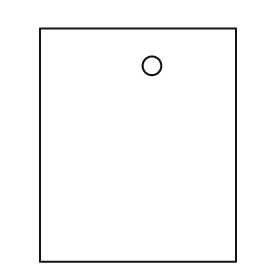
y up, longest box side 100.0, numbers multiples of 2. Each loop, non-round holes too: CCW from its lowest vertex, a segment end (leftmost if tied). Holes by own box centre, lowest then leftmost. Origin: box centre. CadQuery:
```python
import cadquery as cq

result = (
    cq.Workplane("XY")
    .moveTo(-42.0, -50.0)
    .lineTo(42.0, -50.0)
    .lineTo(42.0, 50.0)
    .lineTo(-42.0, 50.0)
    .close()
    .moveTo(6.0, 34.0)
    .circle(4.0)
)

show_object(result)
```